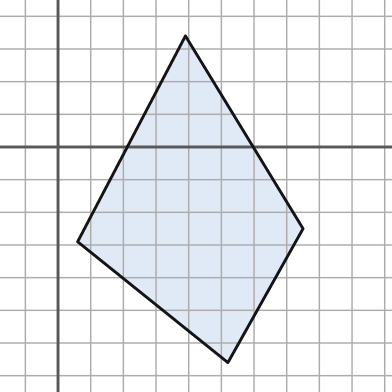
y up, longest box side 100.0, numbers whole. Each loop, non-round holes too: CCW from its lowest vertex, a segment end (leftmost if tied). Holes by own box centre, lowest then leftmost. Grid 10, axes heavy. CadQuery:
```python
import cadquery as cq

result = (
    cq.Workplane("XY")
    .moveTo(52.0, -66.0)
    .lineTo(75.0, -25.0)
    .lineTo(39.0, 34.0)
    .lineTo(6.0, -29.0)
    .close()
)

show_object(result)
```